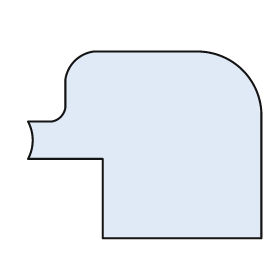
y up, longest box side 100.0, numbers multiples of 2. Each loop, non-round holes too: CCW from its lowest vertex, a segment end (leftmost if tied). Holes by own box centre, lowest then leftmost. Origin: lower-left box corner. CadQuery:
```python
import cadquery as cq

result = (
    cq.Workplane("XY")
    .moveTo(32.0, 0.0)
    .lineTo(100.0, 0.0)
    .lineTo(100.0, 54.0)
    .threePointArc((92.0, 72.0), (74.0, 80.0))
    .lineTo(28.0, 80.0)
    .threePointArc((20.0, 76.0), (16.0, 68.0))
    .lineTo(16.0, 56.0)
    .threePointArc((14.0, 52.0), (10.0, 50.0))
    .lineTo(0.0, 50.0)
    .threePointArc((2.0, 42.0), (0.0, 34.0))
    .lineTo(32.0, 34.0)
    .close()
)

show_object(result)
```